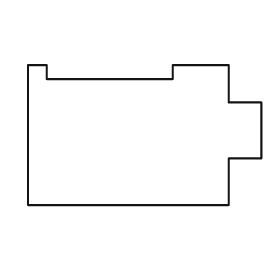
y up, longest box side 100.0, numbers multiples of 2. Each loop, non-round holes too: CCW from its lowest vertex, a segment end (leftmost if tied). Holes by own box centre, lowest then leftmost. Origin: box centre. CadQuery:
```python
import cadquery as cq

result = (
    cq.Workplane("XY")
    .moveTo(-50.0, -30.0)
    .lineTo(36.0, -30.0)
    .lineTo(36.0, -10.0)
    .lineTo(50.0, -10.0)
    .lineTo(50.0, 14.0)
    .lineTo(36.0, 14.0)
    .lineTo(36.0, 30.0)
    .lineTo(12.0, 30.0)
    .lineTo(12.0, 24.0)
    .lineTo(-42.0, 24.0)
    .lineTo(-42.0, 30.0)
    .lineTo(-50.0, 30.0)
    .close()
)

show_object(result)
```